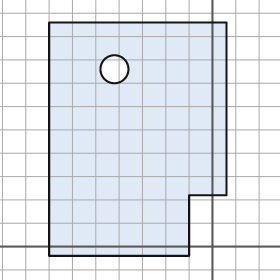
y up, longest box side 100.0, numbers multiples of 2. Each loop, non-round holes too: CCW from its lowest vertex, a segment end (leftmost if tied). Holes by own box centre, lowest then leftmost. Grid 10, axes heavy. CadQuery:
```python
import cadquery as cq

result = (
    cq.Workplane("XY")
    .moveTo(-70.0, -4.0)
    .lineTo(-10.0, -4.0)
    .lineTo(-10.0, 22.0)
    .lineTo(6.0, 22.0)
    .lineTo(6.0, 96.0)
    .lineTo(-70.0, 96.0)
    .close()
    .moveTo(-42.0, 76.0)
    .circle(6.0)
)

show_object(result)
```